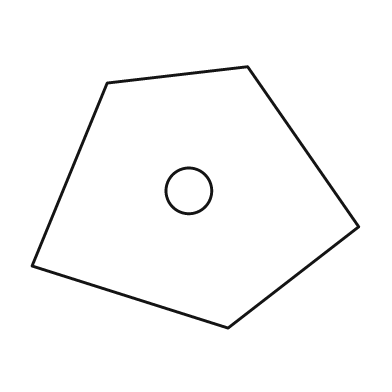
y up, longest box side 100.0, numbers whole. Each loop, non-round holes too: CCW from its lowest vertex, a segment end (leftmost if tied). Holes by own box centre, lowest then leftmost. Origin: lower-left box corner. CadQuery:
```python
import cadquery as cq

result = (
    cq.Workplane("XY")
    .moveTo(60.0, 0.0)
    .lineTo(100.0, 31.0)
    .lineTo(66.0, 80.0)
    .lineTo(23.0, 75.0)
    .lineTo(0.0, 19.0)
    .close()
    .moveTo(48.0, 42.0)
    .circle(7.0)
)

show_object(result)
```